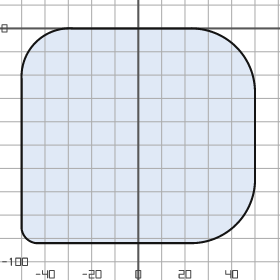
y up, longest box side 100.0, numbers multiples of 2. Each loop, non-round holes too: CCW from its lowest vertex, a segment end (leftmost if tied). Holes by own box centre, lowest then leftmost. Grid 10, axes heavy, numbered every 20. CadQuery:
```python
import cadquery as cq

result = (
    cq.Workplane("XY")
    .moveTo(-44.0, -92.0)
    .lineTo(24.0, -92.0)
    .threePointArc((42.0, -84.0), (50.0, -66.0))
    .lineTo(50.0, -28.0)
    .threePointArc((42.0, -8.0), (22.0, 0.0))
    .lineTo(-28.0, 0.0)
    .threePointArc((-44.0, -6.0), (-50.0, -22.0))
    .lineTo(-50.0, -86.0)
    .threePointArc((-48.0, -90.0), (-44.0, -92.0))
    .close()
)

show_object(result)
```